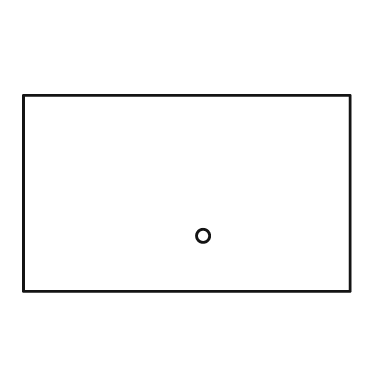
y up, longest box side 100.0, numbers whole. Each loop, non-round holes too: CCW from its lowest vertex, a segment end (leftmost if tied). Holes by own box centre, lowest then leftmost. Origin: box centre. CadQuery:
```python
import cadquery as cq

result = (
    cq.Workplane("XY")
    .moveTo(-50.0, -30.0)
    .lineTo(50.0, -30.0)
    .lineTo(50.0, 30.0)
    .lineTo(-50.0, 30.0)
    .close()
    .moveTo(5.0, -13.0)
    .circle(2.0)
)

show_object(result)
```